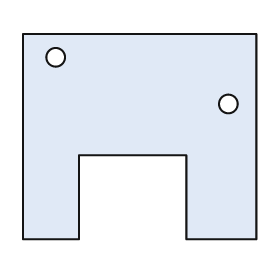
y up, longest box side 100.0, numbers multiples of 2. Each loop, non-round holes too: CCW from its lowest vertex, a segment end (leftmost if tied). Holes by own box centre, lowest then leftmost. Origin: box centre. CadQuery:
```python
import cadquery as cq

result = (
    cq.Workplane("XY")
    .moveTo(-50.0, -44.0)
    .lineTo(-26.0, -44.0)
    .lineTo(-26.0, -8.0)
    .lineTo(20.0, -8.0)
    .lineTo(20.0, -44.0)
    .lineTo(50.0, -44.0)
    .lineTo(50.0, 44.0)
    .lineTo(-50.0, 44.0)
    .close()
    .moveTo(38.0, 14.0)
    .circle(4.0)
    .moveTo(-36.0, 34.0)
    .circle(4.0)
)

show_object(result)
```